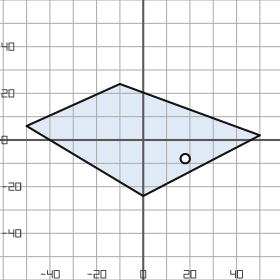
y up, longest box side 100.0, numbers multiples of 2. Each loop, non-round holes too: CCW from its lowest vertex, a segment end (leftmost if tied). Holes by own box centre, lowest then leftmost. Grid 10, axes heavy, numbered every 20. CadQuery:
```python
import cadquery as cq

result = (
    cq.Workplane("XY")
    .moveTo(0.0, -24.0)
    .lineTo(50.0, 2.0)
    .lineTo(-10.0, 24.0)
    .lineTo(-50.0, 6.0)
    .close()
    .moveTo(18.0, -8.0)
    .circle(2.0)
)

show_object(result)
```